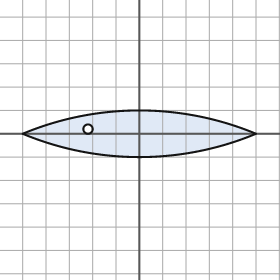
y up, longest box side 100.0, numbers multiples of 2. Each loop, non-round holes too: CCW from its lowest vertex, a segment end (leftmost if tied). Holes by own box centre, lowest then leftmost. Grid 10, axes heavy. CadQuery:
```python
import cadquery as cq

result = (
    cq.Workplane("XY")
    .moveTo(-50.0, 0.0)
    .threePointArc((0.0, -10.0), (50.0, 0.0))
    .threePointArc((0.0, 10.0), (-50.0, 0.0))
    .close()
    .moveTo(-22.0, 2.0)
    .circle(2.0)
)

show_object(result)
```